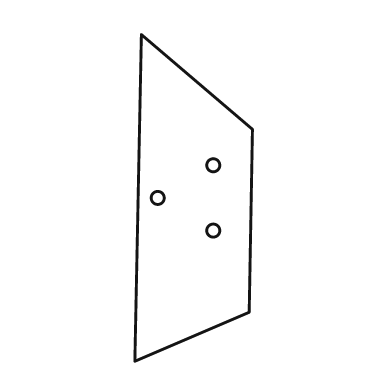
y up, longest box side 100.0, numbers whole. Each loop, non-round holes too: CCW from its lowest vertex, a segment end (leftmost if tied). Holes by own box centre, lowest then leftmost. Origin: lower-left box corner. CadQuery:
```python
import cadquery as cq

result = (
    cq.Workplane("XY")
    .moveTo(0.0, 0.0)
    .lineTo(35.0, 15.0)
    .lineTo(36.0, 71.0)
    .lineTo(2.0, 100.0)
    .close()
    .moveTo(24.0, 40.0)
    .circle(2.0)
    .moveTo(7.0, 50.0)
    .circle(2.0)
    .moveTo(24.0, 60.0)
    .circle(2.0)
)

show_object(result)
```